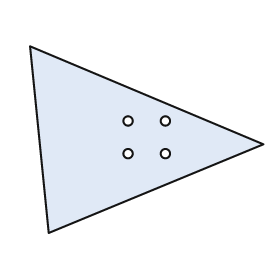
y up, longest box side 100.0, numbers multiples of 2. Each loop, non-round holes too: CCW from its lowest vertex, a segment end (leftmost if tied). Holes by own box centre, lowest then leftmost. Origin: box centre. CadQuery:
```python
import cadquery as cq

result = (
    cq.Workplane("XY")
    .moveTo(-42.0, -40.0)
    .lineTo(50.0, -2.0)
    .lineTo(-50.0, 40.0)
    .close()
    .moveTo(-8.0, -6.0)
    .circle(2.0)
    .moveTo(8.0, -6.0)
    .circle(2.0)
    .moveTo(-8.0, 8.0)
    .circle(2.0)
    .moveTo(8.0, 8.0)
    .circle(2.0)
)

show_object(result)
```